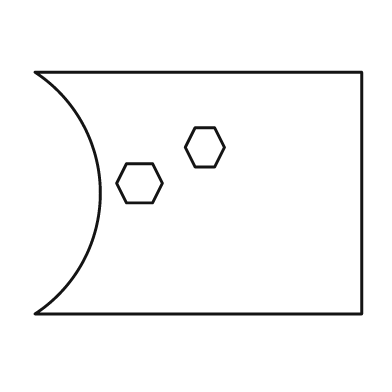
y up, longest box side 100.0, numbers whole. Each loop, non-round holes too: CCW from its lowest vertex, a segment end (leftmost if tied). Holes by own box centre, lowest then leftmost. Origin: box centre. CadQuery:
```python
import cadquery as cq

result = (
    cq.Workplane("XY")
    .moveTo(-50.0, -37.0)
    .lineTo(50.0, -37.0)
    .lineTo(50.0, 37.0)
    .lineTo(-50.0, 37.0)
    .threePointArc((-30.0, 0.0), (-50.0, -37.0))
    .close()
    .moveTo(-22.0, -3.0)
    .lineTo(-14.0, -3.0)
    .lineTo(-11.0, 3.0)
    .lineTo(-14.0, 9.0)
    .lineTo(-22.0, 9.0)
    .lineTo(-25.0, 3.0)
    .close()
    .moveTo(-1.0, 8.0)
    .lineTo(5.0, 8.0)
    .lineTo(8.0, 14.0)
    .lineTo(5.0, 20.0)
    .lineTo(-1.0, 20.0)
    .lineTo(-4.0, 14.0)
    .close()
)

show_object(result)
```